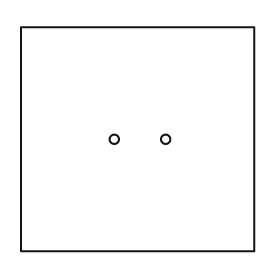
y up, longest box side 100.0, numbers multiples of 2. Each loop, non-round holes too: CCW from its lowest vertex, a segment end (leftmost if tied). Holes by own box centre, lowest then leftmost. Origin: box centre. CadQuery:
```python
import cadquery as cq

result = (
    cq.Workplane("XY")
    .moveTo(-50.0, -48.0)
    .lineTo(50.0, -48.0)
    .lineTo(50.0, 48.0)
    .lineTo(-50.0, 48.0)
    .close()
    .moveTo(-10.0, 0.0)
    .circle(2.0)
    .moveTo(12.0, 0.0)
    .circle(2.0)
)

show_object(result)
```